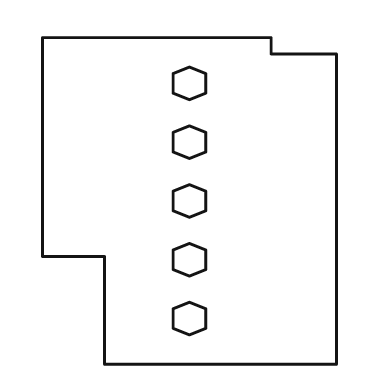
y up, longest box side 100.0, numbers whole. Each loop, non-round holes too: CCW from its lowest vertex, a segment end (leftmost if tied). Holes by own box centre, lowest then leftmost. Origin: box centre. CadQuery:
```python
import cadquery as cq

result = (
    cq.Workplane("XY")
    .moveTo(-26.0, -50.0)
    .lineTo(45.0, -50.0)
    .lineTo(45.0, 45.0)
    .lineTo(25.0, 45.0)
    .lineTo(25.0, 50.0)
    .lineTo(-45.0, 50.0)
    .lineTo(-45.0, -17.0)
    .lineTo(-26.0, -17.0)
    .close()
    .moveTo(0.0, -41.0)
    .lineTo(5.0, -39.0)
    .lineTo(5.0, -33.0)
    .lineTo(0.0, -31.0)
    .lineTo(-5.0, -33.0)
    .lineTo(-5.0, -39.0)
    .close()
    .moveTo(0.0, -23.0)
    .lineTo(5.0, -21.0)
    .lineTo(5.0, -15.0)
    .lineTo(0.0, -13.0)
    .lineTo(-5.0, -15.0)
    .lineTo(-5.0, -21.0)
    .close()
    .moveTo(0.0, -5.0)
    .lineTo(5.0, -3.0)
    .lineTo(5.0, 3.0)
    .lineTo(0.0, 5.0)
    .lineTo(-5.0, 3.0)
    .lineTo(-5.0, -3.0)
    .close()
    .moveTo(0.0, 13.0)
    .lineTo(5.0, 15.0)
    .lineTo(5.0, 21.0)
    .lineTo(0.0, 23.0)
    .lineTo(-5.0, 21.0)
    .lineTo(-5.0, 15.0)
    .close()
    .moveTo(0.0, 31.0)
    .lineTo(5.0, 33.0)
    .lineTo(5.0, 39.0)
    .lineTo(0.0, 41.0)
    .lineTo(-5.0, 39.0)
    .lineTo(-5.0, 33.0)
    .close()
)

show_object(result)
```